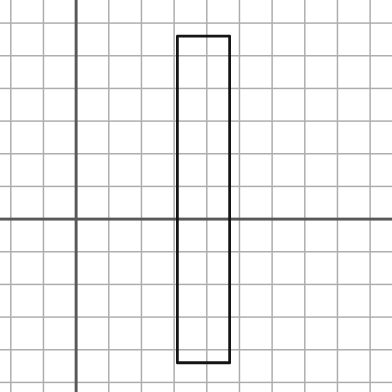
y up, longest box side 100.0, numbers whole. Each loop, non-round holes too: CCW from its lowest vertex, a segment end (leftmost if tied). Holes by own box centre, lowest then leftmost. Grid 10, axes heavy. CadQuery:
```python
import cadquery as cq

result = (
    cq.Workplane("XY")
    .moveTo(31.0, -44.0)
    .lineTo(47.0, -44.0)
    .lineTo(47.0, 56.0)
    .lineTo(31.0, 56.0)
    .close()
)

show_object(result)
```